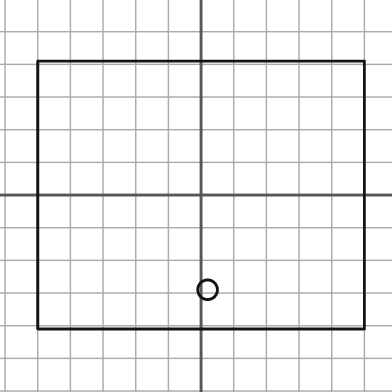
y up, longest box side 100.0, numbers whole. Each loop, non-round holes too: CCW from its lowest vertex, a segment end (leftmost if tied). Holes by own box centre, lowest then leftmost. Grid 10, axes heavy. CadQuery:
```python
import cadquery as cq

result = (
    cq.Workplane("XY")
    .moveTo(-50.0, -41.0)
    .lineTo(50.0, -41.0)
    .lineTo(50.0, 41.0)
    .lineTo(-50.0, 41.0)
    .close()
    .moveTo(2.0, -29.0)
    .circle(3.0)
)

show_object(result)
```